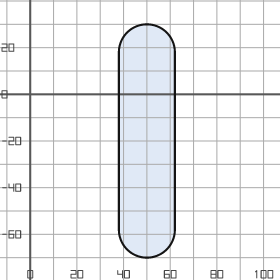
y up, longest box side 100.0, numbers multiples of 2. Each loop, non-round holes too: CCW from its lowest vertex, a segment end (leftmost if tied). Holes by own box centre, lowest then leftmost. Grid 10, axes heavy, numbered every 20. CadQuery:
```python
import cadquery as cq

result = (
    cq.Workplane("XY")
    .moveTo(38.0, -58.0)
    .threePointArc((50.0, -70.0), (62.0, -58.0))
    .lineTo(62.0, 18.0)
    .threePointArc((50.0, 30.0), (38.0, 18.0))
    .close()
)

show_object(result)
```